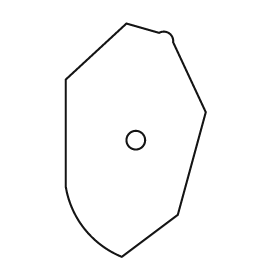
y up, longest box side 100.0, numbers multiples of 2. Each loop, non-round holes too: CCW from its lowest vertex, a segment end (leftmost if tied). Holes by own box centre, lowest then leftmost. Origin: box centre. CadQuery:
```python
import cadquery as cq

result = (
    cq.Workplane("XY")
    .moveTo(-6.0, -50.0)
    .lineTo(18.0, -32.0)
    .lineTo(30.0, 12.0)
    .lineTo(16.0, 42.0)
    .threePointArc((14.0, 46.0), (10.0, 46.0))
    .lineTo(-4.0, 50.0)
    .lineTo(-30.0, 26.0)
    .lineTo(-30.0, -20.0)
    .threePointArc((-22.0, -38.0), (-6.0, -50.0))
    .close()
    .moveTo(0.0, 0.0)
    .circle(4.0)
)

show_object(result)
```